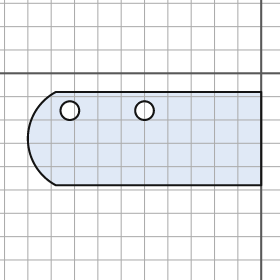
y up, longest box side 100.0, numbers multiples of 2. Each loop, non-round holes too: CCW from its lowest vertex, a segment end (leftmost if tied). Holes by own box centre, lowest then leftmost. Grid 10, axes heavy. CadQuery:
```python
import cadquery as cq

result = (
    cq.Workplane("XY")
    .moveTo(-88.0, -48.0)
    .lineTo(0.0, -48.0)
    .lineTo(0.0, -8.0)
    .lineTo(-88.0, -8.0)
    .threePointArc((-100.0, -28.0), (-88.0, -48.0))
    .close()
    .moveTo(-82.0, -16.0)
    .circle(4.0)
    .moveTo(-50.0, -16.0)
    .circle(4.0)
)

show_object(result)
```